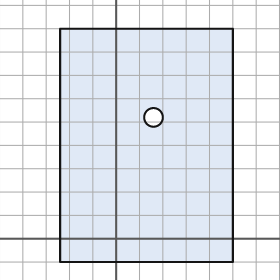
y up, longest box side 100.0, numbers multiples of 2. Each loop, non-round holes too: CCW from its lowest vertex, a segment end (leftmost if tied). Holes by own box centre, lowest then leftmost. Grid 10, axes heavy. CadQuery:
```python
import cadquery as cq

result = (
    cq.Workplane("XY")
    .moveTo(-24.0, -10.0)
    .lineTo(50.0, -10.0)
    .lineTo(50.0, 90.0)
    .lineTo(-24.0, 90.0)
    .close()
    .moveTo(16.0, 52.0)
    .circle(4.0)
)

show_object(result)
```